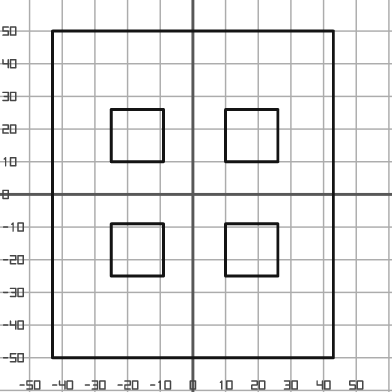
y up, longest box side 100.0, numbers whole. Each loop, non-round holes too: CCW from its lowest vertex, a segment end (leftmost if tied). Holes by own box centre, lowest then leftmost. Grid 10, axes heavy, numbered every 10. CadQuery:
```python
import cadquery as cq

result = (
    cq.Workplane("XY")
    .moveTo(-43.0, -50.0)
    .lineTo(43.0, -50.0)
    .lineTo(43.0, 50.0)
    .lineTo(-43.0, 50.0)
    .close()
    .moveTo(-25.0, -25.0)
    .lineTo(-9.0, -25.0)
    .lineTo(-9.0, -9.0)
    .lineTo(-25.0, -9.0)
    .close()
    .moveTo(10.0, -25.0)
    .lineTo(26.0, -25.0)
    .lineTo(26.0, -9.0)
    .lineTo(10.0, -9.0)
    .close()
    .moveTo(-25.0, 10.0)
    .lineTo(-9.0, 10.0)
    .lineTo(-9.0, 26.0)
    .lineTo(-25.0, 26.0)
    .close()
    .moveTo(10.0, 10.0)
    .lineTo(26.0, 10.0)
    .lineTo(26.0, 26.0)
    .lineTo(10.0, 26.0)
    .close()
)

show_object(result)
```